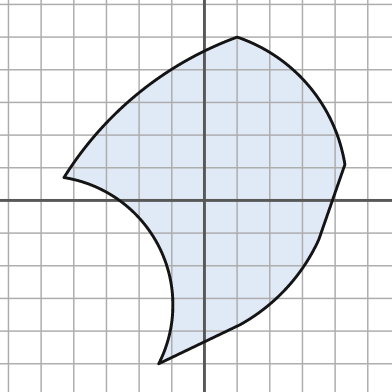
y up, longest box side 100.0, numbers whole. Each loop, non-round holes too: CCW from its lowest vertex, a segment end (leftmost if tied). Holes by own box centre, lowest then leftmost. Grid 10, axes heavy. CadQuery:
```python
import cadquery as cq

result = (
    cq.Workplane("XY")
    .moveTo(-14.0, -50.0)
    .lineTo(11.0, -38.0)
    .threePointArc((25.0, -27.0), (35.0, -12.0))
    .lineTo(43.0, 11.0)
    .threePointArc((32.0, 35.0), (10.0, 50.0))
    .threePointArc((-20.0, 33.0), (-43.0, 7.0))
    .threePointArc((-14.0, -14.0), (-14.0, -50.0))
    .close()
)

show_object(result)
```